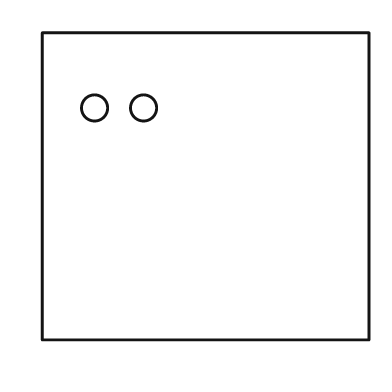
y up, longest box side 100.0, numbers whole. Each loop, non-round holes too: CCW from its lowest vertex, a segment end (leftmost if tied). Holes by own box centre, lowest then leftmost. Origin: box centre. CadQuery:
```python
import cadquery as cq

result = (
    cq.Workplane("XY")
    .moveTo(-50.0, -47.0)
    .lineTo(50.0, -47.0)
    .lineTo(50.0, 47.0)
    .lineTo(-50.0, 47.0)
    .close()
    .moveTo(-34.0, 24.0)
    .circle(4.0)
    .moveTo(-19.0, 24.0)
    .circle(4.0)
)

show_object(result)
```